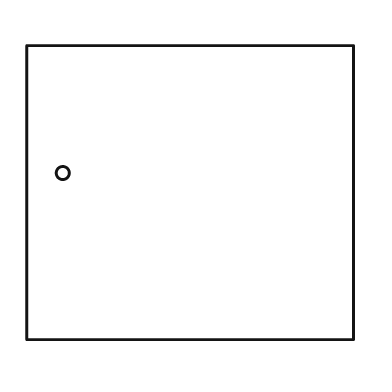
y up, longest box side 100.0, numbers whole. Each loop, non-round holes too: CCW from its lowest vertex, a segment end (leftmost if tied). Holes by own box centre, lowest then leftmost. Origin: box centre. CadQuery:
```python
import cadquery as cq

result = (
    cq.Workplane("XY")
    .moveTo(-50.0, -45.0)
    .lineTo(50.0, -45.0)
    .lineTo(50.0, 45.0)
    .lineTo(-50.0, 45.0)
    .close()
    .moveTo(-39.0, 6.0)
    .circle(2.0)
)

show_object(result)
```